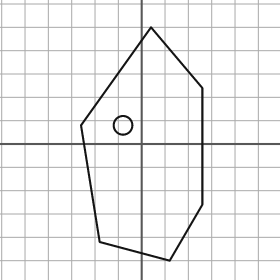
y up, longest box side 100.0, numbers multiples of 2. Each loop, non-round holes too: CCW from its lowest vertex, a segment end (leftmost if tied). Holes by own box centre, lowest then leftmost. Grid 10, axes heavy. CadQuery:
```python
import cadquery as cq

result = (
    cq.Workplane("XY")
    .moveTo(12.0, -50.0)
    .lineTo(26.0, -26.0)
    .lineTo(26.0, 24.0)
    .lineTo(4.0, 50.0)
    .lineTo(-26.0, 8.0)
    .lineTo(-18.0, -42.0)
    .close()
    .moveTo(-8.0, 8.0)
    .circle(4.0)
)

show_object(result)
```